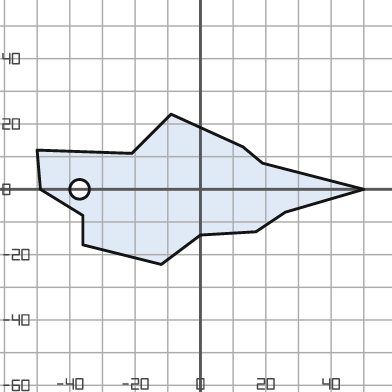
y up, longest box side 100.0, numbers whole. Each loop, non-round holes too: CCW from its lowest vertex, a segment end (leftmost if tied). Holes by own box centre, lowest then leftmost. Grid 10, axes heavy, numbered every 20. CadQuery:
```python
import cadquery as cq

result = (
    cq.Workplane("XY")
    .moveTo(-12.0, -23.0)
    .lineTo(0.0, -14.0)
    .lineTo(17.0, -13.0)
    .lineTo(26.0, -7.0)
    .lineTo(50.0, 0.0)
    .lineTo(19.0, 8.0)
    .lineTo(13.0, 13.0)
    .lineTo(-9.0, 23.0)
    .lineTo(-21.0, 11.0)
    .lineTo(-50.0, 12.0)
    .lineTo(-49.0, 0.0)
    .lineTo(-36.0, -8.0)
    .lineTo(-36.0, -17.0)
    .close()
    .moveTo(-37.0, 0.0)
    .circle(3.0)
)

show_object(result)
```